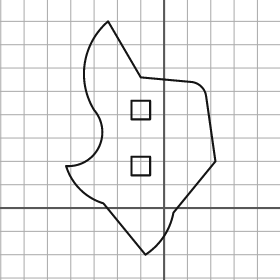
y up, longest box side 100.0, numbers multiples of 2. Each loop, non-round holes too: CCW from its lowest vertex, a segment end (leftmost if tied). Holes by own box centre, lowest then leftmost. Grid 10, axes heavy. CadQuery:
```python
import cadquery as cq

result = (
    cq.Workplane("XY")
    .moveTo(-8.0, -20.0)
    .threePointArc((0.0, -12.0), (4.0, -2.0))
    .lineTo(22.0, 20.0)
    .lineTo(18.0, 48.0)
    .threePointArc((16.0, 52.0), (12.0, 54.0))
    .lineTo(-10.0, 56.0)
    .lineTo(-24.0, 80.0)
    .threePointArc((-34.0, 62.0), (-30.0, 42.0))
    .threePointArc((-28.0, 26.0), (-42.0, 18.0))
    .threePointArc((-36.0, 8.0), (-26.0, 2.0))
    .close()
    .moveTo(-14.0, 14.0)
    .lineTo(-6.0, 14.0)
    .lineTo(-6.0, 22.0)
    .lineTo(-14.0, 22.0)
    .close()
    .moveTo(-14.0, 38.0)
    .lineTo(-6.0, 38.0)
    .lineTo(-6.0, 46.0)
    .lineTo(-14.0, 46.0)
    .close()
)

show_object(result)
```